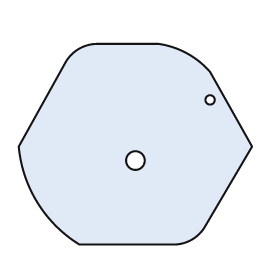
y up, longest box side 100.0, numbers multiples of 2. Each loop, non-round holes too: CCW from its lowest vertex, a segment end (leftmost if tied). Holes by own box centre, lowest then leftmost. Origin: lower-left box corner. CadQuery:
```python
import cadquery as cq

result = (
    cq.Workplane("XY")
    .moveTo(26.0, 0.0)
    .lineTo(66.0, 0.0)
    .threePointArc((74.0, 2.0), (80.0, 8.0))
    .lineTo(100.0, 42.0)
    .lineTo(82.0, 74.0)
    .threePointArc((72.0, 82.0), (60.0, 86.0))
    .lineTo(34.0, 86.0)
    .threePointArc((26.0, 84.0), (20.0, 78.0))
    .lineTo(0.0, 42.0)
    .threePointArc((8.0, 18.0), (26.0, 0.0))
    .close()
    .moveTo(50.0, 36.0)
    .circle(4.0)
    .moveTo(82.0, 62.0)
    .circle(2.0)
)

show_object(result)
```